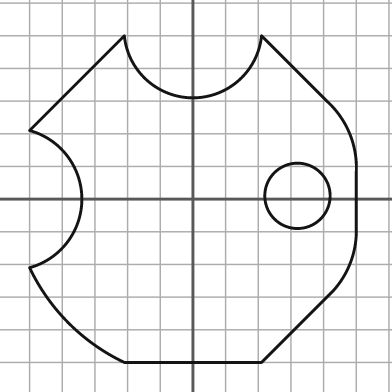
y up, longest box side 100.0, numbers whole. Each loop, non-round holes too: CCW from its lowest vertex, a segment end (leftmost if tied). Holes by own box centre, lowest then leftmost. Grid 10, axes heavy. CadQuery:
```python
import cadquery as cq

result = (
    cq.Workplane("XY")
    .moveTo(-21.0, -50.0)
    .lineTo(21.0, -50.0)
    .lineTo(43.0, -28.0)
    .threePointArc((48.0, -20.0), (50.0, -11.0))
    .lineTo(50.0, 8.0)
    .threePointArc((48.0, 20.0), (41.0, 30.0))
    .lineTo(21.0, 50.0)
    .threePointArc((0.0, 31.0), (-21.0, 50.0))
    .lineTo(-50.0, 21.0)
    .threePointArc((-34.0, 0.0), (-50.0, -21.0))
    .threePointArc((-38.0, -38.0), (-21.0, -50.0))
    .close()
    .moveTo(32.0, 1.0)
    .circle(10.0)
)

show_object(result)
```